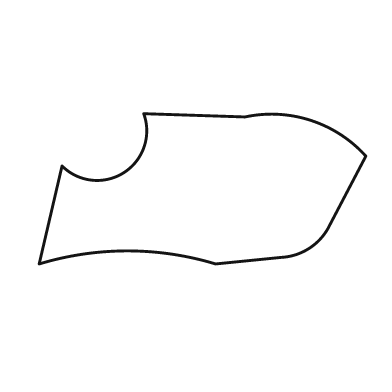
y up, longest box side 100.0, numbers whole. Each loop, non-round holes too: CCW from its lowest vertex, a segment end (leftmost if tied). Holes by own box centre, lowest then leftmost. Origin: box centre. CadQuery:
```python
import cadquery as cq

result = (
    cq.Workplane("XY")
    .moveTo(-50.0, -23.0)
    .threePointArc((-23.0, -19.0), (4.0, -23.0))
    .lineTo(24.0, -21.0)
    .threePointArc((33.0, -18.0), (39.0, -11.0))
    .lineTo(50.0, 10.0)
    .threePointArc((33.0, 21.0), (13.0, 22.0))
    .lineTo(-18.0, 23.0)
    .threePointArc((-24.0, 5.0), (-43.0, 7.0))
    .close()
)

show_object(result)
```